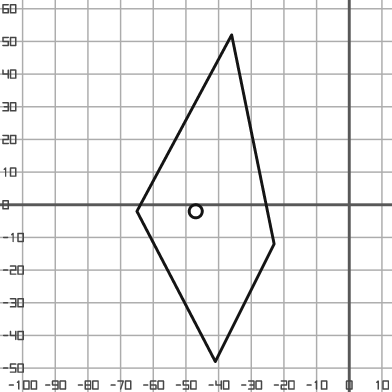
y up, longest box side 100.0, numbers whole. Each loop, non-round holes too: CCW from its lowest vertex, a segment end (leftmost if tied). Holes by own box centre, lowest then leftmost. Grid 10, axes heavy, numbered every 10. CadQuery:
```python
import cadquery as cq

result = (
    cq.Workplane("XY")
    .moveTo(-41.0, -48.0)
    .lineTo(-23.0, -12.0)
    .lineTo(-36.0, 52.0)
    .lineTo(-65.0, -2.0)
    .close()
    .moveTo(-47.0, -2.0)
    .circle(2.0)
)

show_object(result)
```